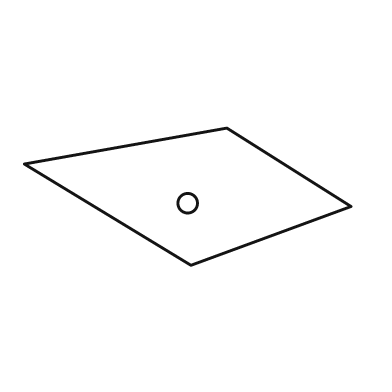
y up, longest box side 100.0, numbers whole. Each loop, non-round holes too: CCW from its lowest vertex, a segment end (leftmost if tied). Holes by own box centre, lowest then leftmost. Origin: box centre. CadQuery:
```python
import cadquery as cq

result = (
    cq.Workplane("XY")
    .moveTo(1.0, -21.0)
    .lineTo(50.0, -3.0)
    .lineTo(12.0, 21.0)
    .lineTo(-50.0, 10.0)
    .close()
    .moveTo(0.0, -2.0)
    .circle(3.0)
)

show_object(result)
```